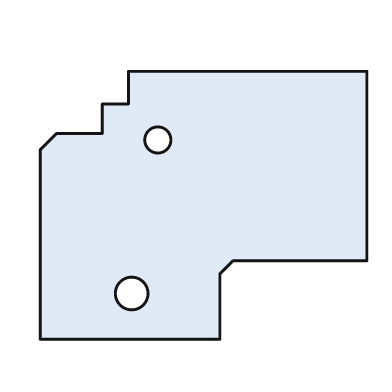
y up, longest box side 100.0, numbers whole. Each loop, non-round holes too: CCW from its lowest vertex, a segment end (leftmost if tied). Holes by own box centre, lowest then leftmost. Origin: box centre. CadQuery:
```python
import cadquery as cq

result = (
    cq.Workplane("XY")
    .moveTo(-50.0, -41.0)
    .lineTo(5.0, -41.0)
    .lineTo(5.0, -21.0)
    .lineTo(9.0, -17.0)
    .lineTo(50.0, -17.0)
    .lineTo(50.0, 41.0)
    .lineTo(-23.0, 41.0)
    .lineTo(-23.0, 31.0)
    .lineTo(-31.0, 31.0)
    .lineTo(-31.0, 22.0)
    .lineTo(-45.0, 22.0)
    .lineTo(-50.0, 17.0)
    .close()
    .moveTo(-22.0, -27.0)
    .circle(5.0)
    .moveTo(-14.0, 20.0)
    .circle(4.0)
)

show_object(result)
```